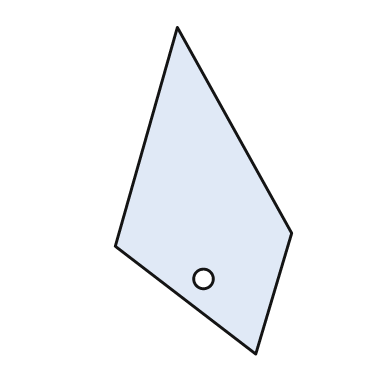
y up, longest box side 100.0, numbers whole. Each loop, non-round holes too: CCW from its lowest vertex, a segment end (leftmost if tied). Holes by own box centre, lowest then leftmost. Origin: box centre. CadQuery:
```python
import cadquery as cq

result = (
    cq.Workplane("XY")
    .moveTo(16.0, -50.0)
    .lineTo(27.0, -13.0)
    .lineTo(-8.0, 50.0)
    .lineTo(-27.0, -17.0)
    .close()
    .moveTo(0.0, -27.0)
    .circle(3.0)
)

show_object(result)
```